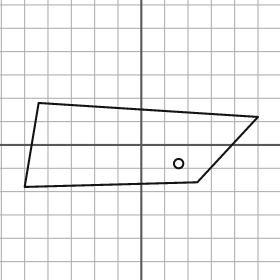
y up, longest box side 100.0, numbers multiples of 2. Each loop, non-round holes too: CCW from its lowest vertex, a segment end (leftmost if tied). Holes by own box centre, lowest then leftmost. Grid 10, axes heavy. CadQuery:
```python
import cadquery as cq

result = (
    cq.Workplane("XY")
    .moveTo(-50.0, -18.0)
    .lineTo(24.0, -16.0)
    .lineTo(50.0, 12.0)
    .lineTo(-44.0, 18.0)
    .close()
    .moveTo(16.0, -8.0)
    .circle(2.0)
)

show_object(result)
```